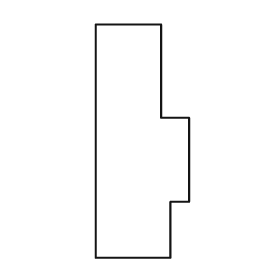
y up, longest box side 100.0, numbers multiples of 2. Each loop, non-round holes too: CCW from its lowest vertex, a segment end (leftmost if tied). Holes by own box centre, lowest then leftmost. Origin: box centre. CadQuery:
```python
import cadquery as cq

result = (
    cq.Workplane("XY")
    .moveTo(-20.0, -50.0)
    .lineTo(12.0, -50.0)
    .lineTo(12.0, -26.0)
    .lineTo(20.0, -26.0)
    .lineTo(20.0, 10.0)
    .lineTo(8.0, 10.0)
    .lineTo(8.0, 50.0)
    .lineTo(-20.0, 50.0)
    .close()
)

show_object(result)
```